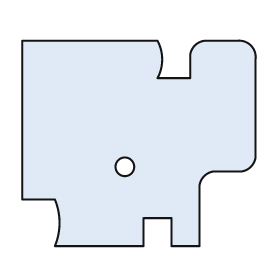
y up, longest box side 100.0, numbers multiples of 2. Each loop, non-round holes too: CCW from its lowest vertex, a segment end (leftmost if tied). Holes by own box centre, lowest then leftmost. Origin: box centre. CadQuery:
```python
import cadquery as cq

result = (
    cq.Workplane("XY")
    .moveTo(-36.0, -44.0)
    .lineTo(2.0, -44.0)
    .lineTo(2.0, -32.0)
    .lineTo(14.0, -32.0)
    .lineTo(14.0, -44.0)
    .lineTo(26.0, -44.0)
    .lineTo(26.0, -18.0)
    .threePointArc((28.0, -14.0), (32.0, -12.0))
    .lineTo(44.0, -12.0)
    .threePointArc((48.0, -10.0), (50.0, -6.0))
    .lineTo(50.0, 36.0)
    .threePointArc((48.0, 42.0), (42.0, 44.0))
    .lineTo(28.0, 44.0)
    .threePointArc((24.0, 42.0), (22.0, 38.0))
    .lineTo(22.0, 28.0)
    .lineTo(8.0, 28.0)
    .threePointArc((10.0, 36.0), (8.0, 44.0))
    .lineTo(-50.0, 44.0)
    .lineTo(-50.0, -24.0)
    .lineTo(-36.0, -24.0)
    .threePointArc((-34.0, -34.0), (-36.0, -44.0))
    .close()
    .moveTo(-6.0, -10.0)
    .circle(4.0)
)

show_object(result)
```